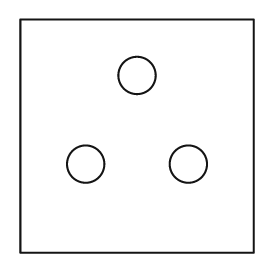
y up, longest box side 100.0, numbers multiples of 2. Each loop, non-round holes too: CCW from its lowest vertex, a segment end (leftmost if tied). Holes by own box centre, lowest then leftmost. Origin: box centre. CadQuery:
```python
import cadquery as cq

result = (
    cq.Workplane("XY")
    .moveTo(-50.0, -50.0)
    .lineTo(50.0, -50.0)
    .lineTo(50.0, 50.0)
    .lineTo(-50.0, 50.0)
    .close()
    .moveTo(-22.0, -12.0)
    .circle(8.0)
    .moveTo(22.0, -12.0)
    .circle(8.0)
    .moveTo(0.0, 26.0)
    .circle(8.0)
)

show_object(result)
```